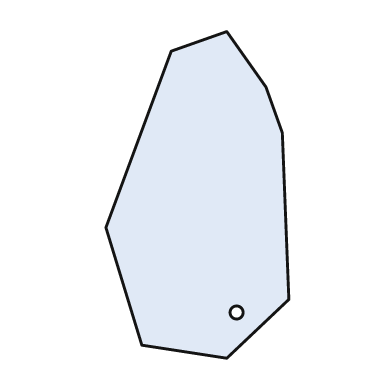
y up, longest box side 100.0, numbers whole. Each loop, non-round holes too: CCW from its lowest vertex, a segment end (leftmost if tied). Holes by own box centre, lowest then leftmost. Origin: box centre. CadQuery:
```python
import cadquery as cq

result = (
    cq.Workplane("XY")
    .moveTo(9.0, -50.0)
    .lineTo(28.0, -32.0)
    .lineTo(26.0, 19.0)
    .lineTo(21.0, 33.0)
    .lineTo(9.0, 50.0)
    .lineTo(-8.0, 44.0)
    .lineTo(-28.0, -10.0)
    .lineTo(-17.0, -46.0)
    .close()
    .moveTo(12.0, -36.0)
    .circle(2.0)
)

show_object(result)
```